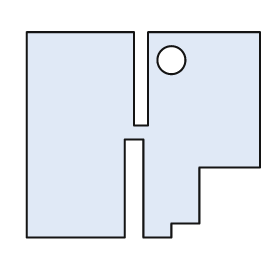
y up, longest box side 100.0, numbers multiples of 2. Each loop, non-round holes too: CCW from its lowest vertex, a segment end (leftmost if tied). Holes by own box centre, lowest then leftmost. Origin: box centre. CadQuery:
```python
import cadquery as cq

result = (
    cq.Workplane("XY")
    .moveTo(-50.0, -44.0)
    .lineTo(-8.0, -44.0)
    .lineTo(-8.0, -2.0)
    .lineTo(0.0, -2.0)
    .lineTo(0.0, -44.0)
    .lineTo(12.0, -44.0)
    .lineTo(12.0, -38.0)
    .lineTo(24.0, -38.0)
    .lineTo(24.0, -14.0)
    .lineTo(50.0, -14.0)
    .lineTo(50.0, 44.0)
    .lineTo(2.0, 44.0)
    .lineTo(2.0, 4.0)
    .lineTo(-4.0, 4.0)
    .lineTo(-4.0, 44.0)
    .lineTo(-50.0, 44.0)
    .close()
    .moveTo(12.0, 32.0)
    .circle(6.0)
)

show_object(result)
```